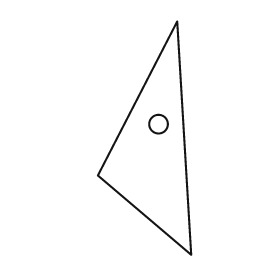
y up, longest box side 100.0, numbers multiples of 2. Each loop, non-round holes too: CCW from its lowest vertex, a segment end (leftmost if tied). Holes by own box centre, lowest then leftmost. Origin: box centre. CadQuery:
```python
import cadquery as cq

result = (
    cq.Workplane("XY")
    .moveTo(20.0, -50.0)
    .lineTo(14.0, 50.0)
    .lineTo(-20.0, -16.0)
    .close()
    .moveTo(6.0, 6.0)
    .circle(4.0)
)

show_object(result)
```